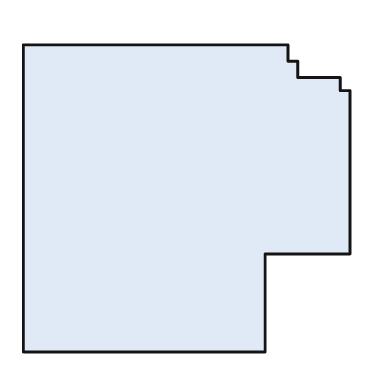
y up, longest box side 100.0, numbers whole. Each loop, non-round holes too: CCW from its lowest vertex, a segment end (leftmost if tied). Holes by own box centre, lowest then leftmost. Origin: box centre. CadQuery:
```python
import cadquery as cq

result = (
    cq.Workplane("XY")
    .moveTo(-50.0, -47.0)
    .lineTo(24.0, -47.0)
    .lineTo(24.0, -17.0)
    .lineTo(50.0, -17.0)
    .lineTo(50.0, 33.0)
    .lineTo(47.0, 33.0)
    .lineTo(47.0, 37.0)
    .lineTo(34.0, 37.0)
    .lineTo(34.0, 42.0)
    .lineTo(31.0, 42.0)
    .lineTo(31.0, 47.0)
    .lineTo(-50.0, 47.0)
    .close()
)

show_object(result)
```